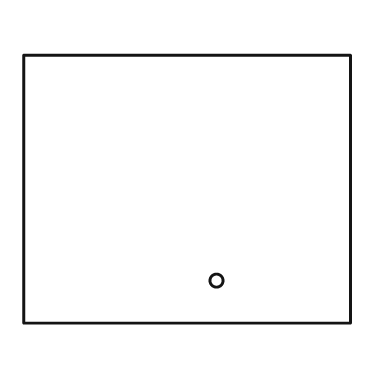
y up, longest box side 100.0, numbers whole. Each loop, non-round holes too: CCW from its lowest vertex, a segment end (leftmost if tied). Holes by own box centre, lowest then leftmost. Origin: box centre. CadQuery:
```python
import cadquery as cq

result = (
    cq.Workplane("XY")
    .moveTo(-50.0, -41.0)
    .lineTo(50.0, -41.0)
    .lineTo(50.0, 41.0)
    .lineTo(-50.0, 41.0)
    .close()
    .moveTo(9.0, -28.0)
    .circle(2.0)
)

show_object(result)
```